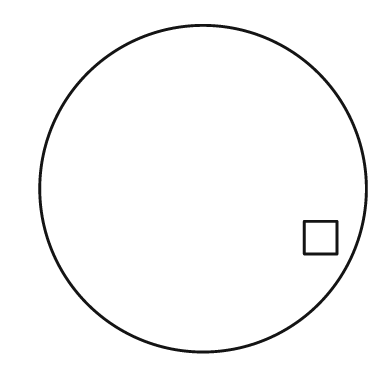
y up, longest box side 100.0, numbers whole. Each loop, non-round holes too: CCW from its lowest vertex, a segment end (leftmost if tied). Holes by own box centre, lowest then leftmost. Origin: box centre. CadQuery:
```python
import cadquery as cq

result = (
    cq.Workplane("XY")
    .moveTo(0.0, 0.0)
    .circle(50.0)
    .moveTo(31.0, -20.0)
    .lineTo(41.0, -20.0)
    .lineTo(41.0, -10.0)
    .lineTo(31.0, -10.0)
    .close()
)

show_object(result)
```